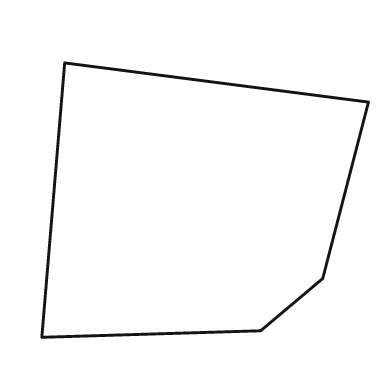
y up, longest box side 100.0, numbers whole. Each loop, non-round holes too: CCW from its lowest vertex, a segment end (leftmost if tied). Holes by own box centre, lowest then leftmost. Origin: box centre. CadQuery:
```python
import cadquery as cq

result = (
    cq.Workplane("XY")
    .moveTo(-50.0, -42.0)
    .lineTo(17.0, -40.0)
    .lineTo(36.0, -24.0)
    .lineTo(50.0, 30.0)
    .lineTo(-43.0, 42.0)
    .close()
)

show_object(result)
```